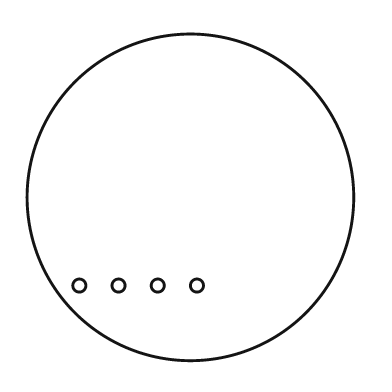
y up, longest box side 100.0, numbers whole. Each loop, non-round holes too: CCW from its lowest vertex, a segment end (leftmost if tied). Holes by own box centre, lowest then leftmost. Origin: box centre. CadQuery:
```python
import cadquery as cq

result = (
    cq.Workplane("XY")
    .moveTo(0.0, 0.0)
    .circle(50.0)
    .moveTo(-34.0, -27.0)
    .circle(2.0)
    .moveTo(-22.0, -27.0)
    .circle(2.0)
    .moveTo(-10.0, -27.0)
    .circle(2.0)
    .moveTo(2.0, -27.0)
    .circle(2.0)
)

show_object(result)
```